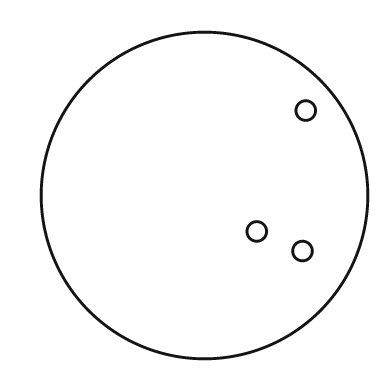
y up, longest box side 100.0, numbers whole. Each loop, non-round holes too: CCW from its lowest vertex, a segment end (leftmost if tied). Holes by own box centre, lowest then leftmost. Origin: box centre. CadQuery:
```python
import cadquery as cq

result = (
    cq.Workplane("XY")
    .moveTo(0.0, 0.0)
    .circle(50.0)
    .moveTo(30.0, -17.0)
    .circle(3.0)
    .moveTo(16.0, -11.0)
    .circle(3.0)
    .moveTo(31.0, 26.0)
    .circle(3.0)
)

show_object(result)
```